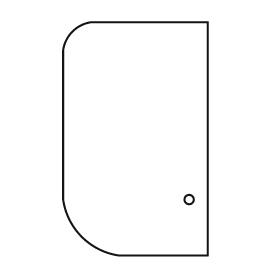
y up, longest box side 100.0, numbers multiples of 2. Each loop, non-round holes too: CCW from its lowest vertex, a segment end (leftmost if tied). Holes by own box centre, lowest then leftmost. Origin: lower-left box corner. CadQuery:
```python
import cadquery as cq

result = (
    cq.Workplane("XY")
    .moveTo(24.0, 0.0)
    .lineTo(62.0, 0.0)
    .lineTo(62.0, 100.0)
    .lineTo(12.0, 100.0)
    .threePointArc((4.0, 96.0), (0.0, 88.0))
    .lineTo(0.0, 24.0)
    .threePointArc((8.0, 8.0), (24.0, 0.0))
    .close()
    .moveTo(54.0, 24.0)
    .circle(2.0)
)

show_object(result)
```